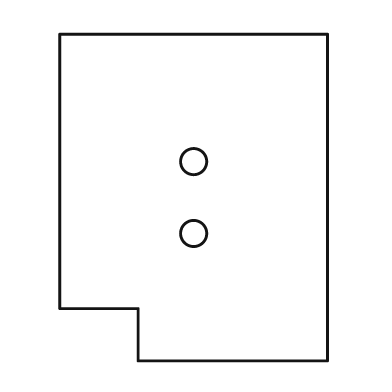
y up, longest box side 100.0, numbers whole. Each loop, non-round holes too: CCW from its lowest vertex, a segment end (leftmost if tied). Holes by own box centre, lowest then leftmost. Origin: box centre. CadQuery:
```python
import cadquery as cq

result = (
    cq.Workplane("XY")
    .moveTo(-17.0, -50.0)
    .lineTo(41.0, -50.0)
    .lineTo(41.0, 50.0)
    .lineTo(-41.0, 50.0)
    .lineTo(-41.0, -34.0)
    .lineTo(-17.0, -34.0)
    .close()
    .moveTo(0.0, -11.0)
    .circle(4.0)
    .moveTo(0.0, 11.0)
    .circle(4.0)
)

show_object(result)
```